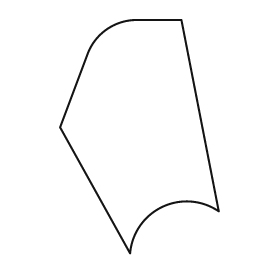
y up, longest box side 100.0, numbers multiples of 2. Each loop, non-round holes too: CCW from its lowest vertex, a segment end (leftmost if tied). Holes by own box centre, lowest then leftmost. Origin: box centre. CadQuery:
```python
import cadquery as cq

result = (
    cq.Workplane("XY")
    .moveTo(-4.0, -50.0)
    .threePointArc((10.0, -30.0), (34.0, -32.0))
    .lineTo(18.0, 50.0)
    .lineTo(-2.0, 50.0)
    .threePointArc((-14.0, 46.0), (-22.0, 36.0))
    .lineTo(-34.0, 4.0)
    .close()
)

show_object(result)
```